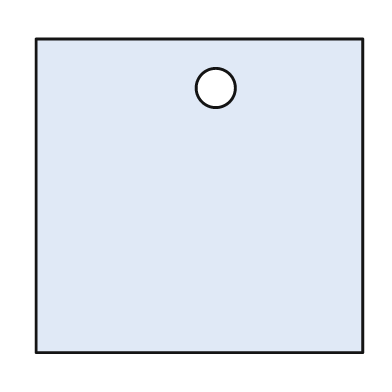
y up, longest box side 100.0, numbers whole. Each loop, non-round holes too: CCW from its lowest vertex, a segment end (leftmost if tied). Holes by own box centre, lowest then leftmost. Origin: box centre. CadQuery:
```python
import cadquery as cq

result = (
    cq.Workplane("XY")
    .moveTo(-50.0, -48.0)
    .lineTo(50.0, -48.0)
    .lineTo(50.0, 48.0)
    .lineTo(-50.0, 48.0)
    .close()
    .moveTo(5.0, 33.0)
    .circle(6.0)
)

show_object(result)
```